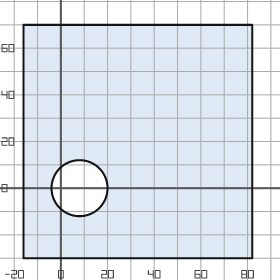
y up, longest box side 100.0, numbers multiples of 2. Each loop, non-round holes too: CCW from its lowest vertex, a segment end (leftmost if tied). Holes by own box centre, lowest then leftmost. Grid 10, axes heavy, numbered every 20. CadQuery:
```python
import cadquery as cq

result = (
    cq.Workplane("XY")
    .moveTo(-16.0, -30.0)
    .lineTo(82.0, -30.0)
    .lineTo(82.0, 70.0)
    .lineTo(-16.0, 70.0)
    .close()
    .moveTo(8.0, 0.0)
    .circle(12.0)
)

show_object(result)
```